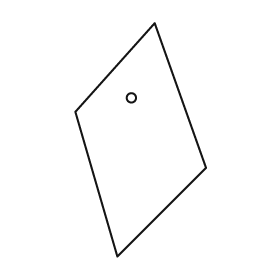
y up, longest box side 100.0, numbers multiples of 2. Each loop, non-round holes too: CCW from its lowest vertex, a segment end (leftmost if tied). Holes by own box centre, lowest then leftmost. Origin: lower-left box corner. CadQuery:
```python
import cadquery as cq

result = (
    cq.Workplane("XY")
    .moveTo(18.0, 0.0)
    .lineTo(56.0, 38.0)
    .lineTo(34.0, 100.0)
    .lineTo(0.0, 62.0)
    .close()
    .moveTo(24.0, 68.0)
    .circle(2.0)
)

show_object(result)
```